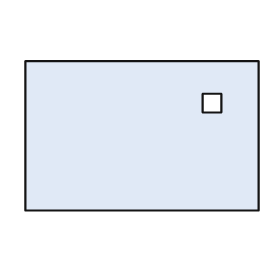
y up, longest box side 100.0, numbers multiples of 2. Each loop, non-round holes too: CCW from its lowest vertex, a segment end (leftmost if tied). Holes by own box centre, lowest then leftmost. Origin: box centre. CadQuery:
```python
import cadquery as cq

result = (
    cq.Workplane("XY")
    .moveTo(-50.0, -32.0)
    .lineTo(50.0, -32.0)
    .lineTo(50.0, 32.0)
    .lineTo(-50.0, 32.0)
    .close()
    .moveTo(26.0, 10.0)
    .lineTo(34.0, 10.0)
    .lineTo(34.0, 18.0)
    .lineTo(26.0, 18.0)
    .close()
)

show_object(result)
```